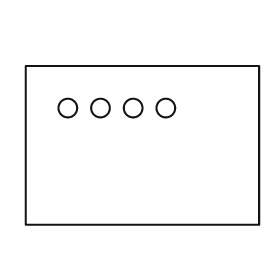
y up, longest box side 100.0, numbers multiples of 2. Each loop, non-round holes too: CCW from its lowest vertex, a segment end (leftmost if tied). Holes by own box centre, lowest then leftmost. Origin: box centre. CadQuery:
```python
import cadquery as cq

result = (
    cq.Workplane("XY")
    .moveTo(-50.0, -34.0)
    .lineTo(50.0, -34.0)
    .lineTo(50.0, 34.0)
    .lineTo(-50.0, 34.0)
    .close()
    .moveTo(-32.0, 16.0)
    .circle(4.0)
    .moveTo(-18.0, 16.0)
    .circle(4.0)
    .moveTo(-4.0, 16.0)
    .circle(4.0)
    .moveTo(10.0, 16.0)
    .circle(4.0)
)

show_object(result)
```